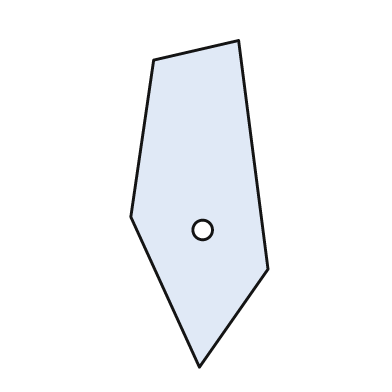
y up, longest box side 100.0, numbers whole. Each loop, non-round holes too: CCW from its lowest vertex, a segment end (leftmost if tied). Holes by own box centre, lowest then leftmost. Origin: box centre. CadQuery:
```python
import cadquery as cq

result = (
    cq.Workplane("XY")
    .moveTo(0.0, -50.0)
    .lineTo(21.0, -20.0)
    .lineTo(12.0, 50.0)
    .lineTo(-14.0, 44.0)
    .lineTo(-21.0, -4.0)
    .close()
    .moveTo(1.0, -8.0)
    .circle(3.0)
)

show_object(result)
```